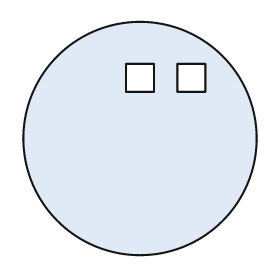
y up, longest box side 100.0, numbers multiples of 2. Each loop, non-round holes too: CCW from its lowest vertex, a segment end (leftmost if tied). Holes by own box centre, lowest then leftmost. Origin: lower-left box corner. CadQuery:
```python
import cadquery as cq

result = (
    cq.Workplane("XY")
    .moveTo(50.0, 50.0)
    .circle(50.0)
    .moveTo(44.0, 70.0)
    .lineTo(56.0, 70.0)
    .lineTo(56.0, 82.0)
    .lineTo(44.0, 82.0)
    .close()
    .moveTo(66.0, 70.0)
    .lineTo(78.0, 70.0)
    .lineTo(78.0, 82.0)
    .lineTo(66.0, 82.0)
    .close()
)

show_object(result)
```